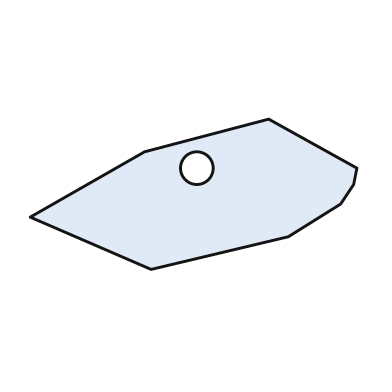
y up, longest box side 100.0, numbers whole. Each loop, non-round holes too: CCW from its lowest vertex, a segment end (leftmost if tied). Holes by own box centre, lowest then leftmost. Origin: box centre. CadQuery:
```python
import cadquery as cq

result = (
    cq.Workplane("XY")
    .moveTo(-13.0, -23.0)
    .lineTo(29.0, -13.0)
    .lineTo(45.0, -3.0)
    .lineTo(49.0, 3.0)
    .lineTo(50.0, 8.0)
    .lineTo(23.0, 23.0)
    .lineTo(-15.0, 13.0)
    .lineTo(-50.0, -7.0)
    .close()
    .moveTo(1.0, 8.0)
    .circle(5.0)
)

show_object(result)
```